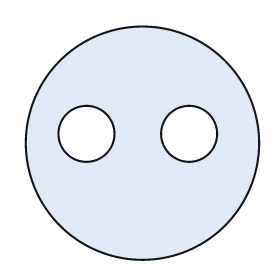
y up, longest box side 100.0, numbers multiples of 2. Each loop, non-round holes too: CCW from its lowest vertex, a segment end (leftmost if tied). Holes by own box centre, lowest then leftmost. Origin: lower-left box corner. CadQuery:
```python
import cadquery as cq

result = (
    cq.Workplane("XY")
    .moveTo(50.0, 50.0)
    .circle(50.0)
    .moveTo(26.0, 54.0)
    .circle(12.0)
    .moveTo(70.0, 54.0)
    .circle(12.0)
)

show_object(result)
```